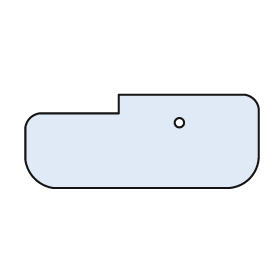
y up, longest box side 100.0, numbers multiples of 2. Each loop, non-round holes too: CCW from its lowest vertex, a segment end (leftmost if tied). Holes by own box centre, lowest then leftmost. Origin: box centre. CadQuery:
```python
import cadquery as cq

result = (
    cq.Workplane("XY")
    .moveTo(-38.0, -20.0)
    .lineTo(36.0, -20.0)
    .threePointArc((46.0, -16.0), (50.0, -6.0))
    .lineTo(50.0, 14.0)
    .threePointArc((48.0, 18.0), (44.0, 20.0))
    .lineTo(-10.0, 20.0)
    .lineTo(-10.0, 12.0)
    .lineTo(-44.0, 12.0)
    .threePointArc((-48.0, 10.0), (-50.0, 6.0))
    .lineTo(-50.0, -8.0)
    .threePointArc((-46.0, -16.0), (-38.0, -20.0))
    .close()
    .moveTo(16.0, 8.0)
    .circle(2.0)
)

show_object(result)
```